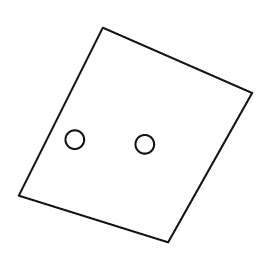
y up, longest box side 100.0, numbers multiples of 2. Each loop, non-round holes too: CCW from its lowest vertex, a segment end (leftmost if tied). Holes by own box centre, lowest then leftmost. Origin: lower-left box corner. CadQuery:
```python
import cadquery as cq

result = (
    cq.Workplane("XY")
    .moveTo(64.0, 0.0)
    .lineTo(100.0, 64.0)
    .lineTo(36.0, 92.0)
    .lineTo(0.0, 20.0)
    .close()
    .moveTo(54.0, 42.0)
    .circle(4.0)
    .moveTo(24.0, 44.0)
    .circle(4.0)
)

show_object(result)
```